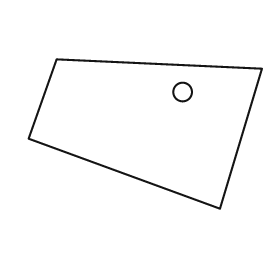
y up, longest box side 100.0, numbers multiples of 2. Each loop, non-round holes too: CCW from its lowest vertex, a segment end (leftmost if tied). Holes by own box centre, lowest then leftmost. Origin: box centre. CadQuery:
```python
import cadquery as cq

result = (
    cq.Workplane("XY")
    .moveTo(32.0, -32.0)
    .lineTo(50.0, 28.0)
    .lineTo(-38.0, 32.0)
    .lineTo(-50.0, -2.0)
    .close()
    .moveTo(16.0, 18.0)
    .circle(4.0)
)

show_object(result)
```